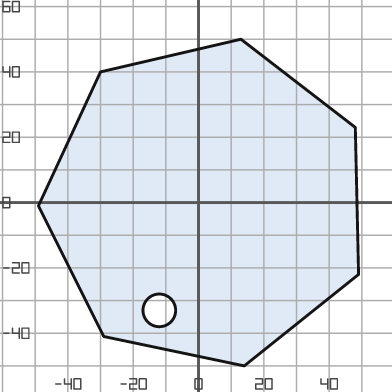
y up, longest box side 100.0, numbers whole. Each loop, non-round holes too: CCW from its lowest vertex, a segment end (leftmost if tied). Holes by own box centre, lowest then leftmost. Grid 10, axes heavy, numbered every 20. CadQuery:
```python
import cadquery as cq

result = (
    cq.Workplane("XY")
    .moveTo(14.0, -50.0)
    .lineTo(49.0, -22.0)
    .lineTo(48.0, 23.0)
    .lineTo(13.0, 50.0)
    .lineTo(-30.0, 40.0)
    .lineTo(-49.0, -1.0)
    .lineTo(-29.0, -41.0)
    .close()
    .moveTo(-12.0, -33.0)
    .circle(5.0)
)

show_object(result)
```